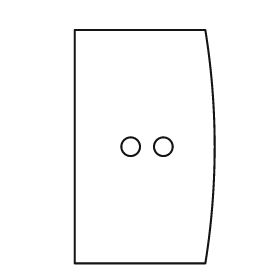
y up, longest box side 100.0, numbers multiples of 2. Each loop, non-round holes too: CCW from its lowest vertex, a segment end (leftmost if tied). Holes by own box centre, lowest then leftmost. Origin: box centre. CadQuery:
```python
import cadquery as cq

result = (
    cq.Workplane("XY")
    .moveTo(-30.0, -50.0)
    .lineTo(26.0, -50.0)
    .threePointArc((30.0, 0.0), (26.0, 50.0))
    .lineTo(-30.0, 50.0)
    .close()
    .moveTo(-6.0, 0.0)
    .circle(4.0)
    .moveTo(8.0, 0.0)
    .circle(4.0)
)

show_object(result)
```